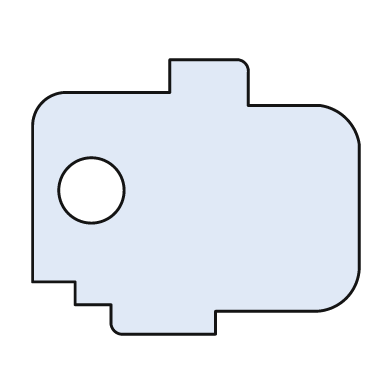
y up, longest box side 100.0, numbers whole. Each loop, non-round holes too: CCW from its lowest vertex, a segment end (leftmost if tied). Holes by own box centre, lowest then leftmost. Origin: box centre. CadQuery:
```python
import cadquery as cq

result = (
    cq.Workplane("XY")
    .moveTo(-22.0, -42.0)
    .lineTo(6.0, -42.0)
    .lineTo(6.0, -35.0)
    .lineTo(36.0, -35.0)
    .threePointArc((46.0, -31.0), (50.0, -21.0))
    .lineTo(50.0, 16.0)
    .threePointArc((46.0, 24.0), (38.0, 28.0))
    .lineTo(16.0, 28.0)
    .lineTo(16.0, 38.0)
    .threePointArc((15.0, 41.0), (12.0, 42.0))
    .lineTo(-8.0, 42.0)
    .lineTo(-8.0, 32.0)
    .lineTo(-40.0, 32.0)
    .threePointArc((-47.0, 29.0), (-50.0, 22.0))
    .lineTo(-50.0, -26.0)
    .lineTo(-37.0, -26.0)
    .lineTo(-37.0, -33.0)
    .lineTo(-26.0, -33.0)
    .lineTo(-26.0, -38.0)
    .threePointArc((-25.0, -41.0), (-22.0, -42.0))
    .close()
    .moveTo(-32.0, 2.0)
    .circle(10.0)
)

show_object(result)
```